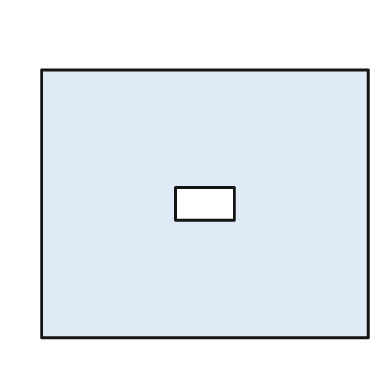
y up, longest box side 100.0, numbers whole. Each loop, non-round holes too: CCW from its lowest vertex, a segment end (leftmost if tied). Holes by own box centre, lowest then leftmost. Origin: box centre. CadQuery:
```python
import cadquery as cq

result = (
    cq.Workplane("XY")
    .moveTo(-50.0, -41.0)
    .lineTo(50.0, -41.0)
    .lineTo(50.0, 41.0)
    .lineTo(-50.0, 41.0)
    .close()
    .moveTo(-9.0, -5.0)
    .lineTo(9.0, -5.0)
    .lineTo(9.0, 5.0)
    .lineTo(-9.0, 5.0)
    .close()
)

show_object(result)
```